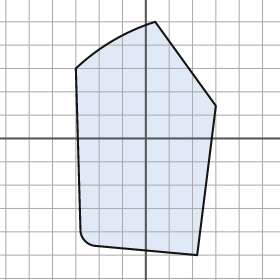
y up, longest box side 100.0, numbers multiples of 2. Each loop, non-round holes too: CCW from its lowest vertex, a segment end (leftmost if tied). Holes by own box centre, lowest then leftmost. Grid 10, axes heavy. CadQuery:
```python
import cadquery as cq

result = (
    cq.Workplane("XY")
    .moveTo(22.0, -50.0)
    .lineTo(30.0, 14.0)
    .lineTo(4.0, 50.0)
    .threePointArc((-14.0, 42.0), (-30.0, 30.0))
    .lineTo(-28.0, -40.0)
    .threePointArc((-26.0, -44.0), (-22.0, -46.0))
    .close()
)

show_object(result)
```